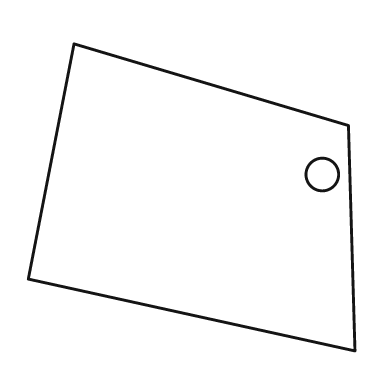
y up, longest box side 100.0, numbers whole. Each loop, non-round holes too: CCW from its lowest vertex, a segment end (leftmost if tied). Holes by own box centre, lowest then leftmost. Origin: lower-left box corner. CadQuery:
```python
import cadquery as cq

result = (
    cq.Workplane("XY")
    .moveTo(100.0, 0.0)
    .lineTo(98.0, 69.0)
    .lineTo(14.0, 94.0)
    .lineTo(0.0, 22.0)
    .close()
    .moveTo(90.0, 54.0)
    .circle(5.0)
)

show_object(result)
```